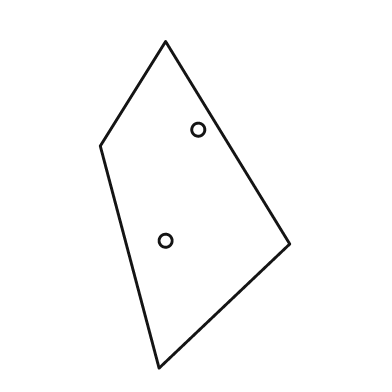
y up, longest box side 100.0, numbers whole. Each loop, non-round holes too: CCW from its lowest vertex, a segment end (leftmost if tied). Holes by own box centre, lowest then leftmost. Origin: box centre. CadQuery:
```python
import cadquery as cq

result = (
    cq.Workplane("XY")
    .moveTo(-11.0, -50.0)
    .lineTo(29.0, -12.0)
    .lineTo(-9.0, 50.0)
    .lineTo(-29.0, 18.0)
    .close()
    .moveTo(-9.0, -11.0)
    .circle(2.0)
    .moveTo(1.0, 23.0)
    .circle(2.0)
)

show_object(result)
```